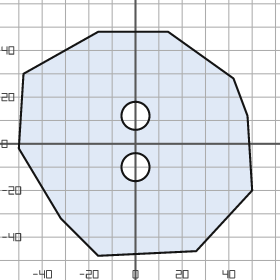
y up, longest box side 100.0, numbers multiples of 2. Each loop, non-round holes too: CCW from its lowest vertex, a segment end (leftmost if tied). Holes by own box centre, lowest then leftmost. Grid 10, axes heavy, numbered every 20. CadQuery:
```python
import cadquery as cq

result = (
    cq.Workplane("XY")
    .moveTo(-16.0, -48.0)
    .lineTo(26.0, -46.0)
    .lineTo(50.0, -20.0)
    .lineTo(48.0, 12.0)
    .lineTo(42.0, 28.0)
    .lineTo(14.0, 48.0)
    .lineTo(-16.0, 48.0)
    .lineTo(-48.0, 30.0)
    .lineTo(-50.0, -2.0)
    .lineTo(-32.0, -32.0)
    .close()
    .moveTo(0.0, -10.0)
    .circle(6.0)
    .moveTo(0.0, 12.0)
    .circle(6.0)
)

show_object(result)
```